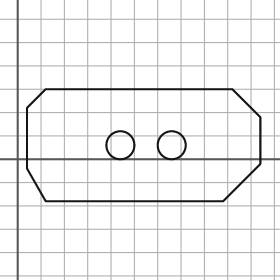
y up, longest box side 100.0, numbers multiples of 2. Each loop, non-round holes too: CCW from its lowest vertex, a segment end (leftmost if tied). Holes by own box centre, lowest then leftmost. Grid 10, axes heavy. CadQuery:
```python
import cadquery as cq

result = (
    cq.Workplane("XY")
    .moveTo(12.0, -18.0)
    .lineTo(88.0, -18.0)
    .lineTo(104.0, -2.0)
    .lineTo(104.0, 18.0)
    .lineTo(92.0, 30.0)
    .lineTo(12.0, 30.0)
    .lineTo(4.0, 22.0)
    .lineTo(4.0, -4.0)
    .close()
    .moveTo(44.0, 6.0)
    .circle(6.0)
    .moveTo(66.0, 6.0)
    .circle(6.0)
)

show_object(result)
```